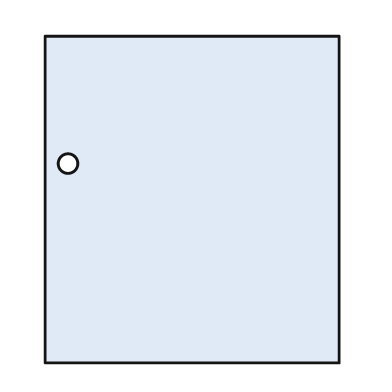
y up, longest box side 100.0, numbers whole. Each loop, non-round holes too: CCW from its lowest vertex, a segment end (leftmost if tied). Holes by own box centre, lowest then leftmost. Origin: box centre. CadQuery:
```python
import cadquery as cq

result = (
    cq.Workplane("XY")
    .moveTo(-45.0, -50.0)
    .lineTo(45.0, -50.0)
    .lineTo(45.0, 50.0)
    .lineTo(-45.0, 50.0)
    .close()
    .moveTo(-38.0, 11.0)
    .circle(3.0)
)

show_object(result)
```